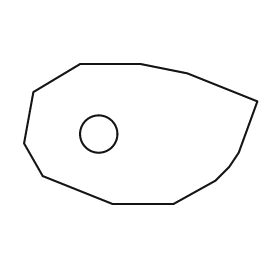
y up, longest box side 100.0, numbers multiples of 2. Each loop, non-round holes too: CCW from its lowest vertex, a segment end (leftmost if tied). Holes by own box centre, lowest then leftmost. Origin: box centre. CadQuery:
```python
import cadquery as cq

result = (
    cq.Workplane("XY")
    .moveTo(-12.0, -30.0)
    .lineTo(14.0, -30.0)
    .lineTo(32.0, -20.0)
    .lineTo(38.0, -14.0)
    .lineTo(42.0, -8.0)
    .lineTo(50.0, 14.0)
    .lineTo(20.0, 26.0)
    .lineTo(0.0, 30.0)
    .lineTo(-26.0, 30.0)
    .lineTo(-46.0, 18.0)
    .lineTo(-50.0, -4.0)
    .lineTo(-42.0, -18.0)
    .close()
    .moveTo(-18.0, 0.0)
    .circle(8.0)
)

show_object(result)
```